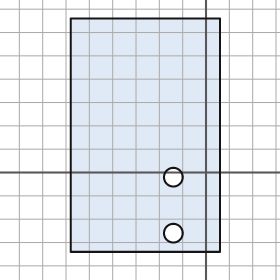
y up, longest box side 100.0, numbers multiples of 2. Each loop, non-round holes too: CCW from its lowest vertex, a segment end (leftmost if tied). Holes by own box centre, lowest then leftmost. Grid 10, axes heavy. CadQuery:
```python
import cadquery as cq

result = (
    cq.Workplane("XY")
    .moveTo(-58.0, -34.0)
    .lineTo(6.0, -34.0)
    .lineTo(6.0, 66.0)
    .lineTo(-58.0, 66.0)
    .close()
    .moveTo(-14.0, -26.0)
    .circle(4.0)
    .moveTo(-14.0, -2.0)
    .circle(4.0)
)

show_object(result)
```